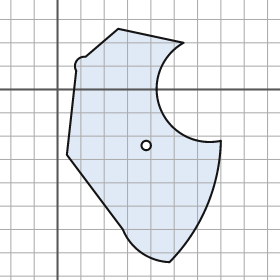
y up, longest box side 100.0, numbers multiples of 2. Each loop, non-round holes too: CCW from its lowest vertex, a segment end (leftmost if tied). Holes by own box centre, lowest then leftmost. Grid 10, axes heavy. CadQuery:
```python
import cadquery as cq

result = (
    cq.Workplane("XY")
    .moveTo(48.0, -74.0)
    .threePointArc((64.0, -50.0), (70.0, -22.0))
    .threePointArc((44.0, -8.0), (54.0, 20.0))
    .lineTo(26.0, 26.0)
    .lineTo(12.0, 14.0)
    .threePointArc((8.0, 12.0), (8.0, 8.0))
    .lineTo(4.0, -28.0)
    .lineTo(28.0, -60.0)
    .threePointArc((36.0, -70.0), (48.0, -74.0))
    .close()
    .moveTo(38.0, -24.0)
    .circle(2.0)
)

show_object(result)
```